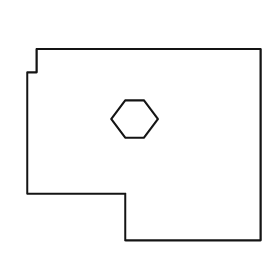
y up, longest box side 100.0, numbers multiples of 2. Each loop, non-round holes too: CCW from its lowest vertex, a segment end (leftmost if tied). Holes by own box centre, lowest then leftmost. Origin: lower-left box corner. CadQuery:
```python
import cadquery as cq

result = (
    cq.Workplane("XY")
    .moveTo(42.0, 0.0)
    .lineTo(100.0, 0.0)
    .lineTo(100.0, 82.0)
    .lineTo(4.0, 82.0)
    .lineTo(4.0, 72.0)
    .lineTo(0.0, 72.0)
    .lineTo(0.0, 20.0)
    .lineTo(42.0, 20.0)
    .close()
    .moveTo(42.0, 44.0)
    .lineTo(50.0, 44.0)
    .lineTo(56.0, 52.0)
    .lineTo(50.0, 60.0)
    .lineTo(42.0, 60.0)
    .lineTo(36.0, 52.0)
    .close()
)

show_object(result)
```